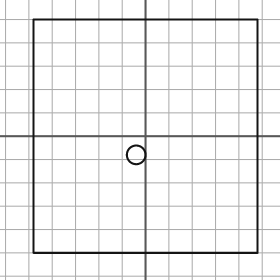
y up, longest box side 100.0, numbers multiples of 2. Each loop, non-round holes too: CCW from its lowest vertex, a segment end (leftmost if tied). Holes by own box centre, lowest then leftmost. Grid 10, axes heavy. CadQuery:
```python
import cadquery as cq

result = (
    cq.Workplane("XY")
    .moveTo(-48.0, -50.0)
    .lineTo(48.0, -50.0)
    .lineTo(48.0, 50.0)
    .lineTo(-48.0, 50.0)
    .close()
    .moveTo(-4.0, -8.0)
    .circle(4.0)
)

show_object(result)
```